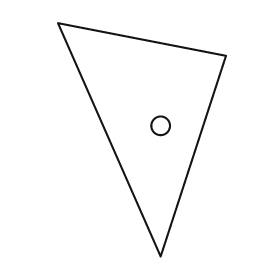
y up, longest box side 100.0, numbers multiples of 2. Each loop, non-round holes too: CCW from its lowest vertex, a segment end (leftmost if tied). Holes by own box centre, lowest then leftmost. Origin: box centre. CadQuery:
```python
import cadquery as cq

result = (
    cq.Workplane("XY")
    .moveTo(8.0, -50.0)
    .lineTo(36.0, 36.0)
    .lineTo(-36.0, 50.0)
    .close()
    .moveTo(8.0, 6.0)
    .circle(4.0)
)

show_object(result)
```